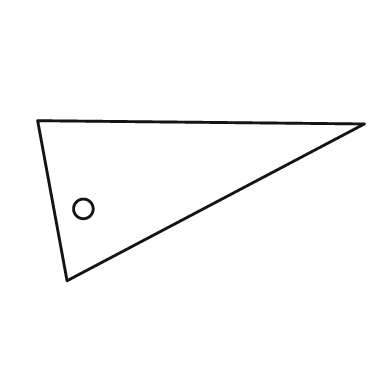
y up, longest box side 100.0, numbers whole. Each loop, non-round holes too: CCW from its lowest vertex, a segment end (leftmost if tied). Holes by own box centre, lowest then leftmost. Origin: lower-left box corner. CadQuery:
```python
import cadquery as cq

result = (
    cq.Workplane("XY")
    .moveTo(9.0, 0.0)
    .lineTo(100.0, 48.0)
    .lineTo(0.0, 49.0)
    .close()
    .moveTo(14.0, 22.0)
    .circle(3.0)
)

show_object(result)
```